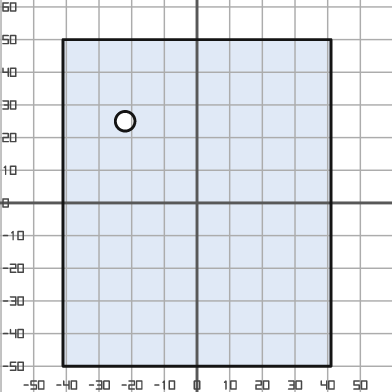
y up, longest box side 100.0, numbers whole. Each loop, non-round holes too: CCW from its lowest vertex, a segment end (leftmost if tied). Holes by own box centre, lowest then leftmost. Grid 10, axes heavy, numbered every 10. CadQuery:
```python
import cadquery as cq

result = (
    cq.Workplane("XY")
    .moveTo(-41.0, -50.0)
    .lineTo(41.0, -50.0)
    .lineTo(41.0, 50.0)
    .lineTo(-41.0, 50.0)
    .close()
    .moveTo(-22.0, 25.0)
    .circle(3.0)
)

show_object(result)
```